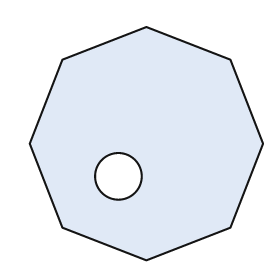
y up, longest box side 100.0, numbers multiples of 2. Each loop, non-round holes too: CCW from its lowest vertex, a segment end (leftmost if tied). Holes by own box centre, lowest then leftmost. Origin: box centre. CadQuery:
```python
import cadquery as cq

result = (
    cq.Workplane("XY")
    .moveTo(0.0, -50.0)
    .lineTo(36.0, -36.0)
    .lineTo(50.0, 0.0)
    .lineTo(36.0, 36.0)
    .lineTo(0.0, 50.0)
    .lineTo(-36.0, 36.0)
    .lineTo(-50.0, 0.0)
    .lineTo(-36.0, -36.0)
    .close()
    .moveTo(-12.0, -14.0)
    .circle(10.0)
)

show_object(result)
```